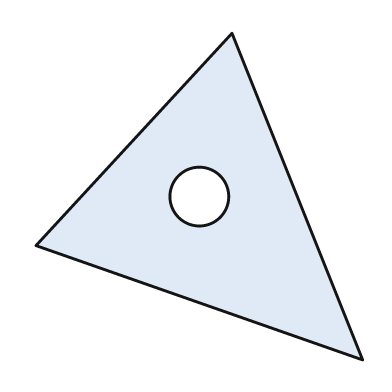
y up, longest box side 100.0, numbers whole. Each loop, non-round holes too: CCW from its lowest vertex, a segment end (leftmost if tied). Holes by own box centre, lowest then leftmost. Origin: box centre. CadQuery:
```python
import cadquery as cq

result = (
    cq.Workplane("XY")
    .moveTo(50.0, -50.0)
    .lineTo(10.0, 50.0)
    .lineTo(-50.0, -15.0)
    .close()
    .moveTo(0.0, 0.0)
    .circle(9.0)
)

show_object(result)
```